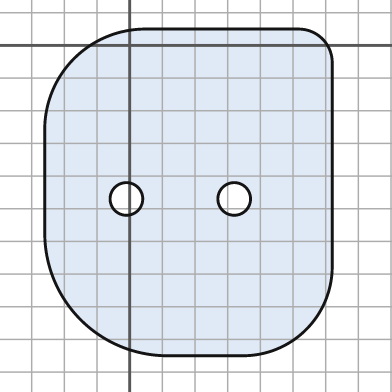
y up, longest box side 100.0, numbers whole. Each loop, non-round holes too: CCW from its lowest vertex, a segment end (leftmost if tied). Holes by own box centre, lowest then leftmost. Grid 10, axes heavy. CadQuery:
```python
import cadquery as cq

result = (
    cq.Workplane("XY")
    .moveTo(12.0, -95.0)
    .lineTo(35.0, -95.0)
    .threePointArc((54.0, -87.0), (62.0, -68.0))
    .lineTo(62.0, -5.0)
    .threePointArc((59.0, 2.0), (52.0, 5.0))
    .lineTo(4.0, 5.0)
    .threePointArc((-17.0, -4.0), (-26.0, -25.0))
    .lineTo(-26.0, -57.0)
    .threePointArc((-15.0, -84.0), (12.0, -95.0))
    .close()
    .moveTo(-1.0, -47.0)
    .circle(5.0)
    .moveTo(32.0, -47.0)
    .circle(5.0)
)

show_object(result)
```